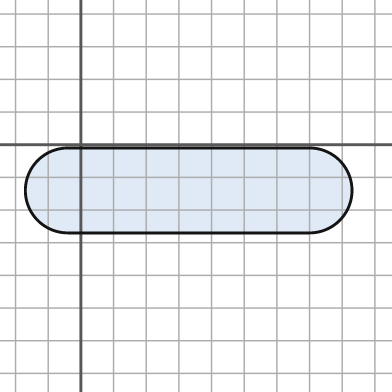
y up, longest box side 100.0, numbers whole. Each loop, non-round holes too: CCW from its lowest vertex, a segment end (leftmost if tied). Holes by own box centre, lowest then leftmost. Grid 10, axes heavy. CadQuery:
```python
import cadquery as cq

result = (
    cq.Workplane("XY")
    .moveTo(-4.0, -27.0)
    .lineTo(70.0, -27.0)
    .threePointArc((83.0, -14.0), (70.0, -1.0))
    .lineTo(-4.0, -1.0)
    .threePointArc((-17.0, -14.0), (-4.0, -27.0))
    .close()
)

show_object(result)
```